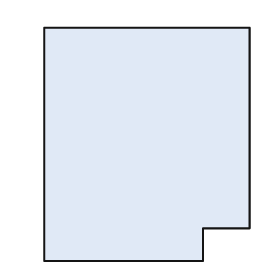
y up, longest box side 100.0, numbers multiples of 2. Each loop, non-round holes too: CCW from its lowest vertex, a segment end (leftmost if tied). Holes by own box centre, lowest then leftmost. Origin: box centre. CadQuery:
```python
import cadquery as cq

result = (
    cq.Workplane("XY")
    .moveTo(-44.0, -50.0)
    .lineTo(24.0, -50.0)
    .lineTo(24.0, -36.0)
    .lineTo(44.0, -36.0)
    .lineTo(44.0, 50.0)
    .lineTo(-44.0, 50.0)
    .close()
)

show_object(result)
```